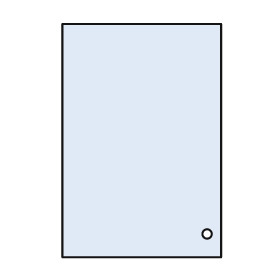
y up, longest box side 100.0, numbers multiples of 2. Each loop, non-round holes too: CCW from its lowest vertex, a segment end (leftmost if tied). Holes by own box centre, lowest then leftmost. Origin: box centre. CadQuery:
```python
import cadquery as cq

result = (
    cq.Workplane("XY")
    .moveTo(-34.0, -50.0)
    .lineTo(34.0, -50.0)
    .lineTo(34.0, 50.0)
    .lineTo(-34.0, 50.0)
    .close()
    .moveTo(28.0, -40.0)
    .circle(2.0)
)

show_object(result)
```